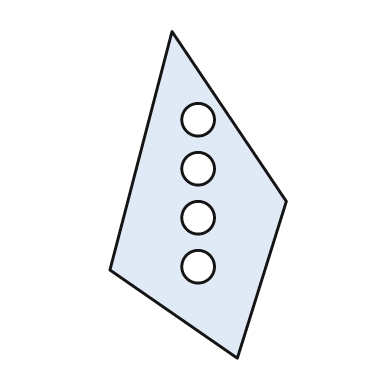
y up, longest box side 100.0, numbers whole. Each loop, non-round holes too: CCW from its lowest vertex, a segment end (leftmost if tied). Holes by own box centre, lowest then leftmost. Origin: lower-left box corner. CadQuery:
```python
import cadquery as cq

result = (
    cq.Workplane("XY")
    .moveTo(39.0, 0.0)
    .lineTo(54.0, 48.0)
    .lineTo(19.0, 100.0)
    .lineTo(0.0, 27.0)
    .close()
    .moveTo(27.0, 28.0)
    .circle(5.0)
    .moveTo(27.0, 43.0)
    .circle(5.0)
    .moveTo(27.0, 58.0)
    .circle(5.0)
    .moveTo(27.0, 73.0)
    .circle(5.0)
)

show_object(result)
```